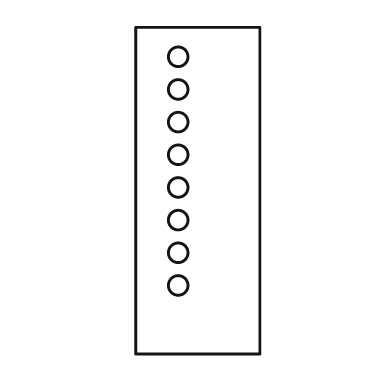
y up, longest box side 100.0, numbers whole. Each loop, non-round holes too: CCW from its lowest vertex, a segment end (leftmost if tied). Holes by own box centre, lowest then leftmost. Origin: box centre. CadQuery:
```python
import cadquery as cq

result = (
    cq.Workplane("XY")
    .moveTo(-19.0, -50.0)
    .lineTo(19.0, -50.0)
    .lineTo(19.0, 50.0)
    .lineTo(-19.0, 50.0)
    .close()
    .moveTo(-6.0, -29.0)
    .circle(3.0)
    .moveTo(-6.0, -19.0)
    .circle(3.0)
    .moveTo(-6.0, -9.0)
    .circle(3.0)
    .moveTo(-6.0, 1.0)
    .circle(3.0)
    .moveTo(-6.0, 11.0)
    .circle(3.0)
    .moveTo(-6.0, 21.0)
    .circle(3.0)
    .moveTo(-6.0, 31.0)
    .circle(3.0)
    .moveTo(-6.0, 41.0)
    .circle(3.0)
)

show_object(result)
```